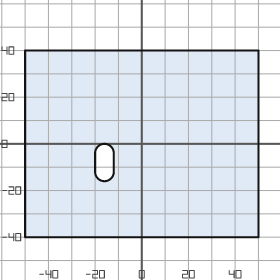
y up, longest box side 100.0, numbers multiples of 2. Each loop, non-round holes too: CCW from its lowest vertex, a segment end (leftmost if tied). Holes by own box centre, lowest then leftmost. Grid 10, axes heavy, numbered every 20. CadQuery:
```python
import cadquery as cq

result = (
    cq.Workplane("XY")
    .moveTo(-50.0, -40.0)
    .lineTo(50.0, -40.0)
    .lineTo(50.0, 40.0)
    .lineTo(-50.0, 40.0)
    .close()
    .moveTo(-20.0, -12.0)
    .threePointArc((-16.0, -16.0), (-12.0, -12.0))
    .lineTo(-12.0, -4.0)
    .threePointArc((-16.0, 0.0), (-20.0, -4.0))
    .close()
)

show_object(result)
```